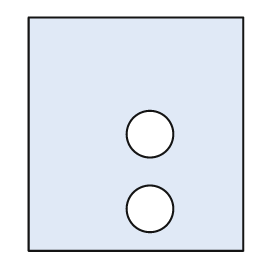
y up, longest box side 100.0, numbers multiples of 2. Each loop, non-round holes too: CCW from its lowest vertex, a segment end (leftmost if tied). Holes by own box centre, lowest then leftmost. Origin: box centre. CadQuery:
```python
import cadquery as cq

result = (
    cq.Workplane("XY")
    .moveTo(-46.0, -50.0)
    .lineTo(46.0, -50.0)
    .lineTo(46.0, 50.0)
    .lineTo(-46.0, 50.0)
    .close()
    .moveTo(6.0, -32.0)
    .circle(10.0)
    .moveTo(6.0, 0.0)
    .circle(10.0)
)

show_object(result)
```